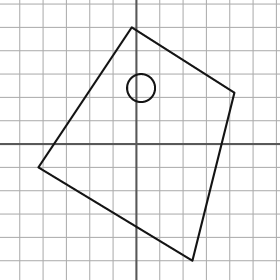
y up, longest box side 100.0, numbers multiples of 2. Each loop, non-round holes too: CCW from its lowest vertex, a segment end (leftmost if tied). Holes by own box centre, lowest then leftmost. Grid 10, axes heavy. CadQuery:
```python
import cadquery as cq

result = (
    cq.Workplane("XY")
    .moveTo(24.0, -50.0)
    .lineTo(42.0, 22.0)
    .lineTo(-2.0, 50.0)
    .lineTo(-42.0, -10.0)
    .close()
    .moveTo(2.0, 24.0)
    .circle(6.0)
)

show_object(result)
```